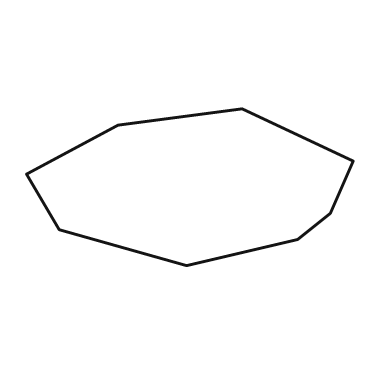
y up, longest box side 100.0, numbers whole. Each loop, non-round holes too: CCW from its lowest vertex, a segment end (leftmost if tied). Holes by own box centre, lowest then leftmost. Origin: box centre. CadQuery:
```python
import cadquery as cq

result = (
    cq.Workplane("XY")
    .moveTo(-1.0, -24.0)
    .lineTo(33.0, -16.0)
    .lineTo(43.0, -8.0)
    .lineTo(50.0, 8.0)
    .lineTo(16.0, 24.0)
    .lineTo(-22.0, 19.0)
    .lineTo(-50.0, 4.0)
    .lineTo(-40.0, -13.0)
    .close()
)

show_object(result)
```